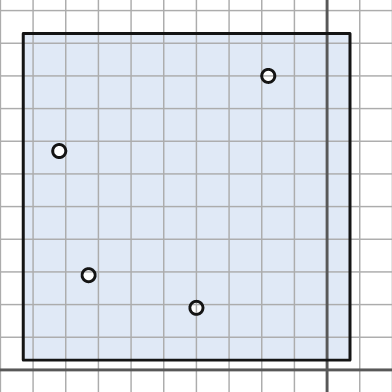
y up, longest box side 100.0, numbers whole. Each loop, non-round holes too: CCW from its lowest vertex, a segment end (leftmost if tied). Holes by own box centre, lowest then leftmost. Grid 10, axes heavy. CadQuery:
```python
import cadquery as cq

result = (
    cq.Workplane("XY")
    .moveTo(-93.0, 3.0)
    .lineTo(7.0, 3.0)
    .lineTo(7.0, 103.0)
    .lineTo(-93.0, 103.0)
    .close()
    .moveTo(-40.0, 19.0)
    .circle(2.0)
    .moveTo(-73.0, 29.0)
    .circle(2.0)
    .moveTo(-82.0, 67.0)
    .circle(2.0)
    .moveTo(-18.0, 90.0)
    .circle(2.0)
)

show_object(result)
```